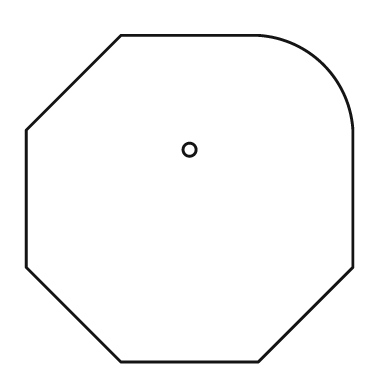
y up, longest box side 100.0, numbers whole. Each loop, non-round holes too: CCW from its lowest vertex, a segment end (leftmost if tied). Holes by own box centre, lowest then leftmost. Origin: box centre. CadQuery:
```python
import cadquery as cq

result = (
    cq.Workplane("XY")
    .moveTo(-21.0, -50.0)
    .lineTo(21.0, -50.0)
    .lineTo(50.0, -21.0)
    .lineTo(50.0, 21.0)
    .threePointArc((41.0, 41.0), (21.0, 50.0))
    .lineTo(-21.0, 50.0)
    .lineTo(-50.0, 21.0)
    .lineTo(-50.0, -21.0)
    .close()
    .moveTo(0.0, 15.0)
    .circle(2.0)
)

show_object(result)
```